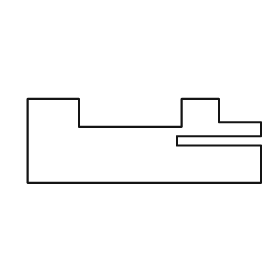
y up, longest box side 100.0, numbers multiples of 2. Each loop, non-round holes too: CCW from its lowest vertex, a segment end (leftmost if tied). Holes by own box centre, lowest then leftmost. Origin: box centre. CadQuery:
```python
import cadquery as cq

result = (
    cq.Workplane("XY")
    .moveTo(-50.0, -18.0)
    .lineTo(50.0, -18.0)
    .lineTo(50.0, -2.0)
    .lineTo(14.0, -2.0)
    .lineTo(14.0, 2.0)
    .lineTo(50.0, 2.0)
    .lineTo(50.0, 8.0)
    .lineTo(32.0, 8.0)
    .lineTo(32.0, 18.0)
    .lineTo(16.0, 18.0)
    .lineTo(16.0, 6.0)
    .lineTo(-28.0, 6.0)
    .lineTo(-28.0, 18.0)
    .lineTo(-50.0, 18.0)
    .close()
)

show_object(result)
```